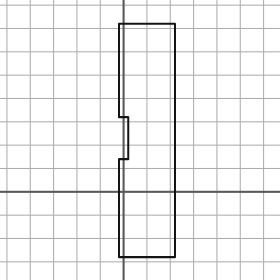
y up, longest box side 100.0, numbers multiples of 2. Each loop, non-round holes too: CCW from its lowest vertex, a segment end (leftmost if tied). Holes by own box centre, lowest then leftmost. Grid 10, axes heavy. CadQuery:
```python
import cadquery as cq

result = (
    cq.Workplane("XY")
    .moveTo(-2.0, -28.0)
    .lineTo(22.0, -28.0)
    .lineTo(22.0, 72.0)
    .lineTo(-2.0, 72.0)
    .lineTo(-2.0, 32.0)
    .lineTo(2.0, 32.0)
    .lineTo(2.0, 14.0)
    .lineTo(-2.0, 14.0)
    .close()
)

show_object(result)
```